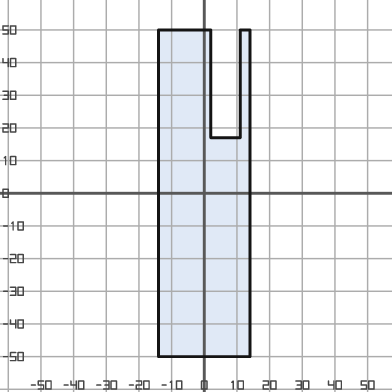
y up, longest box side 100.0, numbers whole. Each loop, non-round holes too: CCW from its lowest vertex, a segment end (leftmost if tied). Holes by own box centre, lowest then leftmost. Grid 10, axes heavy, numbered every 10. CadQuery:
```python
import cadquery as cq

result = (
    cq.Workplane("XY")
    .moveTo(-14.0, -50.0)
    .lineTo(14.0, -50.0)
    .lineTo(14.0, 50.0)
    .lineTo(11.0, 50.0)
    .lineTo(11.0, 17.0)
    .lineTo(2.0, 17.0)
    .lineTo(2.0, 50.0)
    .lineTo(-14.0, 50.0)
    .close()
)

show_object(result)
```